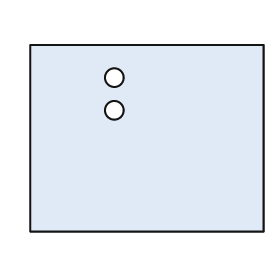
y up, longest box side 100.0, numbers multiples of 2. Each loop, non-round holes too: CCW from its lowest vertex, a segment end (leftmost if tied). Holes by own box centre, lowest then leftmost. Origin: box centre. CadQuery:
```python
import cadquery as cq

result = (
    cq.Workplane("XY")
    .moveTo(-50.0, -40.0)
    .lineTo(50.0, -40.0)
    .lineTo(50.0, 40.0)
    .lineTo(-50.0, 40.0)
    .close()
    .moveTo(-14.0, 12.0)
    .circle(4.0)
    .moveTo(-14.0, 26.0)
    .circle(4.0)
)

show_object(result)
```